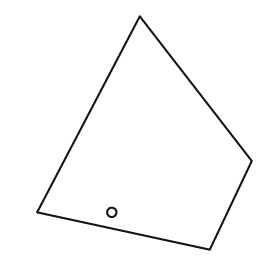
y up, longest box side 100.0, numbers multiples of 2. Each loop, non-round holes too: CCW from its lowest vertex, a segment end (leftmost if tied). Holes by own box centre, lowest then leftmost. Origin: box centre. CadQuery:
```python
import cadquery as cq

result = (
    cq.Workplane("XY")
    .moveTo(28.0, -50.0)
    .lineTo(46.0, -12.0)
    .lineTo(-2.0, 50.0)
    .lineTo(-46.0, -34.0)
    .close()
    .moveTo(-14.0, -34.0)
    .circle(2.0)
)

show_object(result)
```